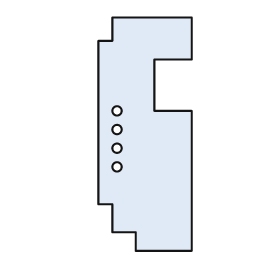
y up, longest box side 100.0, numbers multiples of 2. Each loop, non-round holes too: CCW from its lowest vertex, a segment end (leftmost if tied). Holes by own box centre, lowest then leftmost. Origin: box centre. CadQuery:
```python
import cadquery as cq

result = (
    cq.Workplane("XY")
    .moveTo(-4.0, -50.0)
    .lineTo(20.0, -50.0)
    .lineTo(20.0, 10.0)
    .lineTo(4.0, 10.0)
    .lineTo(4.0, 32.0)
    .lineTo(20.0, 32.0)
    .lineTo(20.0, 50.0)
    .lineTo(-14.0, 50.0)
    .lineTo(-14.0, 40.0)
    .lineTo(-20.0, 40.0)
    .lineTo(-20.0, -30.0)
    .lineTo(-14.0, -30.0)
    .lineTo(-14.0, -42.0)
    .lineTo(-4.0, -42.0)
    .close()
    .moveTo(-12.0, -14.0)
    .circle(2.0)
    .moveTo(-12.0, -6.0)
    .circle(2.0)
    .moveTo(-12.0, 2.0)
    .circle(2.0)
    .moveTo(-12.0, 10.0)
    .circle(2.0)
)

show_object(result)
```